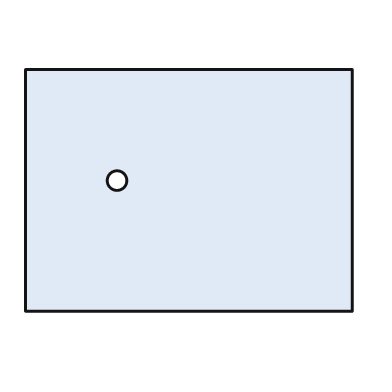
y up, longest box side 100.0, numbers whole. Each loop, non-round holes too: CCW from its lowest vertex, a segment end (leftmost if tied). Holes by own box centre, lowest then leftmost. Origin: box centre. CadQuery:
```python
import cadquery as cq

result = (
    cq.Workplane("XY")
    .moveTo(-50.0, -37.0)
    .lineTo(50.0, -37.0)
    .lineTo(50.0, 37.0)
    .lineTo(-50.0, 37.0)
    .close()
    .moveTo(-22.0, 3.0)
    .circle(3.0)
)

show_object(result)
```